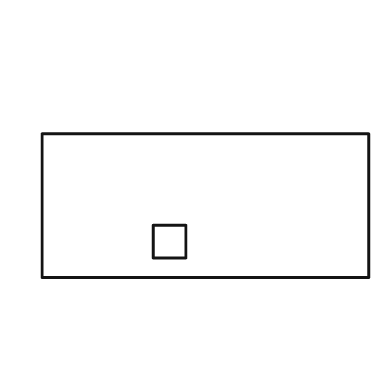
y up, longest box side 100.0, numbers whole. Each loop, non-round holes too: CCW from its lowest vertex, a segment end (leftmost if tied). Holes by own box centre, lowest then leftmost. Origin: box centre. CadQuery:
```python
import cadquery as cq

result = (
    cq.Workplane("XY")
    .moveTo(-50.0, -22.0)
    .lineTo(50.0, -22.0)
    .lineTo(50.0, 22.0)
    .lineTo(-50.0, 22.0)
    .close()
    .moveTo(-16.0, -16.0)
    .lineTo(-6.0, -16.0)
    .lineTo(-6.0, -6.0)
    .lineTo(-16.0, -6.0)
    .close()
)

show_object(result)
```